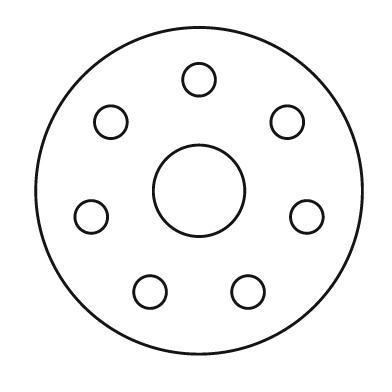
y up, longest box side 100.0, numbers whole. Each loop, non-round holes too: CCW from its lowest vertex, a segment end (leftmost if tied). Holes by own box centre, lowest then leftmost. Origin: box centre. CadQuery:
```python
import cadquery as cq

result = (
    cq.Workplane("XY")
    .moveTo(0.0, 0.0)
    .circle(50.0)
    .moveTo(-15.0, -31.0)
    .circle(5.0)
    .moveTo(15.0, -31.0)
    .circle(5.0)
    .moveTo(-33.0, -8.0)
    .circle(5.0)
    .moveTo(33.0, -8.0)
    .circle(5.0)
    .moveTo(0.0, 0.0)
    .circle(14.0)
    .moveTo(-27.0, 21.0)
    .circle(5.0)
    .moveTo(27.0, 21.0)
    .circle(5.0)
    .moveTo(0.0, 34.0)
    .circle(5.0)
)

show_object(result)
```